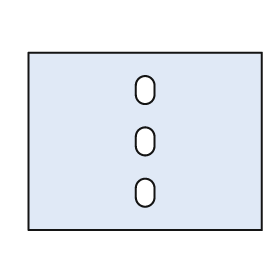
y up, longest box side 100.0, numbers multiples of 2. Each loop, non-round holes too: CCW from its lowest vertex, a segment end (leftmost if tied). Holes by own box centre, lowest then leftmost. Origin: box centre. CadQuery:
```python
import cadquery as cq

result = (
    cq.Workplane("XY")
    .moveTo(-50.0, -38.0)
    .lineTo(50.0, -38.0)
    .lineTo(50.0, 38.0)
    .lineTo(-50.0, 38.0)
    .close()
    .moveTo(-4.0, -24.0)
    .threePointArc((0.0, -28.0), (4.0, -24.0))
    .lineTo(4.0, -20.0)
    .threePointArc((0.0, -16.0), (-4.0, -20.0))
    .close()
    .moveTo(-4.0, -2.0)
    .threePointArc((0.0, -6.0), (4.0, -2.0))
    .lineTo(4.0, 2.0)
    .threePointArc((0.0, 6.0), (-4.0, 2.0))
    .close()
    .moveTo(-4.0, 20.0)
    .threePointArc((0.0, 16.0), (4.0, 20.0))
    .lineTo(4.0, 24.0)
    .threePointArc((0.0, 28.0), (-4.0, 24.0))
    .close()
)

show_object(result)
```